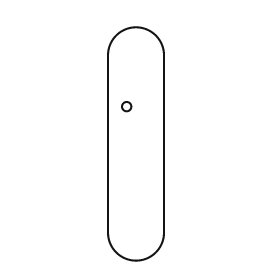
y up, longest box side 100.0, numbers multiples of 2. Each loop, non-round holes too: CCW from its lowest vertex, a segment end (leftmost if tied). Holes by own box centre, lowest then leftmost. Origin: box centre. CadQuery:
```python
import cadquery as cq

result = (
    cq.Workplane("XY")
    .moveTo(-12.0, -38.0)
    .threePointArc((0.0, -50.0), (12.0, -38.0))
    .lineTo(12.0, 38.0)
    .threePointArc((0.0, 50.0), (-12.0, 38.0))
    .close()
    .moveTo(-4.0, 16.0)
    .circle(2.0)
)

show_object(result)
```